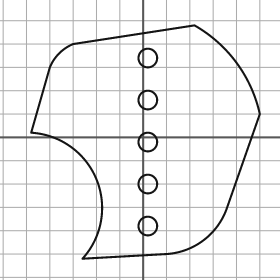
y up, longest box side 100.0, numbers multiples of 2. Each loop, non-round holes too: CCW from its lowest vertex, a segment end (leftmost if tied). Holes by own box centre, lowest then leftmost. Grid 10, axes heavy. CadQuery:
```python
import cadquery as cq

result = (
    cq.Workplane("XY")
    .moveTo(-26.0, -52.0)
    .lineTo(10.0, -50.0)
    .threePointArc((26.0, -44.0), (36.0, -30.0))
    .lineTo(50.0, 10.0)
    .threePointArc((40.0, 32.0), (22.0, 48.0))
    .lineTo(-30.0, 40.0)
    .threePointArc((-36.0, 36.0), (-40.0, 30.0))
    .lineTo(-48.0, 2.0)
    .threePointArc((-20.0, -18.0), (-26.0, -52.0))
    .close()
    .moveTo(2.0, -38.0)
    .circle(4.0)
    .moveTo(2.0, -20.0)
    .circle(4.0)
    .moveTo(2.0, -2.0)
    .circle(4.0)
    .moveTo(2.0, 16.0)
    .circle(4.0)
    .moveTo(2.0, 34.0)
    .circle(4.0)
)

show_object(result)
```